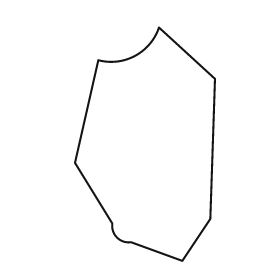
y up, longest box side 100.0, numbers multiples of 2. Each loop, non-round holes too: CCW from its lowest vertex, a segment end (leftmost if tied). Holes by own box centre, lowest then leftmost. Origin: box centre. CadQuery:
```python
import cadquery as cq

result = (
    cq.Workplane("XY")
    .moveTo(16.0, -50.0)
    .lineTo(28.0, -32.0)
    .lineTo(30.0, 28.0)
    .lineTo(6.0, 50.0)
    .threePointArc((-4.0, 38.0), (-20.0, 36.0))
    .lineTo(-30.0, -8.0)
    .lineTo(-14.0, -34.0)
    .threePointArc((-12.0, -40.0), (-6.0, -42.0))
    .close()
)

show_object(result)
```